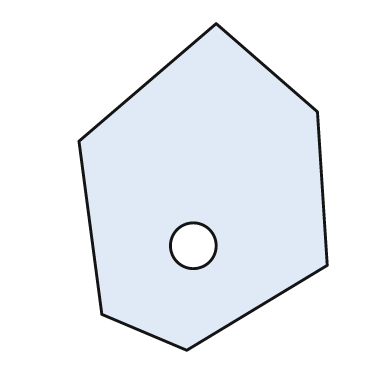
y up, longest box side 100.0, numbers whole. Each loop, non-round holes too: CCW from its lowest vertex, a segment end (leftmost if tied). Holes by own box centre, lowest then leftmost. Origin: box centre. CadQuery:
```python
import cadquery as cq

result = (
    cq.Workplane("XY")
    .moveTo(-5.0, -50.0)
    .lineTo(38.0, -24.0)
    .lineTo(35.0, 23.0)
    .lineTo(4.0, 50.0)
    .lineTo(-38.0, 14.0)
    .lineTo(-31.0, -39.0)
    .close()
    .moveTo(-3.0, -18.0)
    .circle(7.0)
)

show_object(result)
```